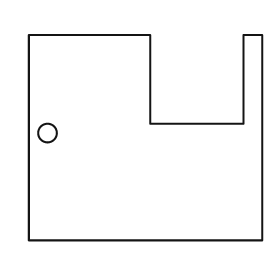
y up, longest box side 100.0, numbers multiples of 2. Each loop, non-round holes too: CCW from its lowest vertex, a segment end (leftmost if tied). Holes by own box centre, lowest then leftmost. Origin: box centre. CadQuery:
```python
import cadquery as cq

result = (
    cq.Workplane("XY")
    .moveTo(-50.0, -44.0)
    .lineTo(50.0, -44.0)
    .lineTo(50.0, 44.0)
    .lineTo(42.0, 44.0)
    .lineTo(42.0, 6.0)
    .lineTo(2.0, 6.0)
    .lineTo(2.0, 44.0)
    .lineTo(-50.0, 44.0)
    .close()
    .moveTo(-42.0, 2.0)
    .circle(4.0)
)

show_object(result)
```